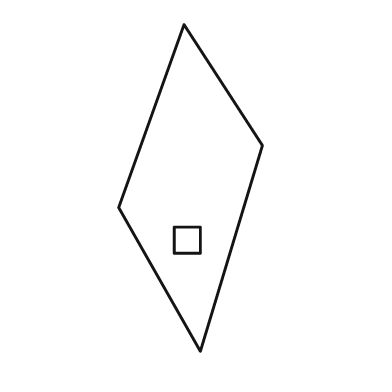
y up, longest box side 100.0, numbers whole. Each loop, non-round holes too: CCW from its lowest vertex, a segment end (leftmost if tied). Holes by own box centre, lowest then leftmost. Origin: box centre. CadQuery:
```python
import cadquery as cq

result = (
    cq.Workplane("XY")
    .moveTo(3.0, -50.0)
    .lineTo(22.0, 13.0)
    .lineTo(-2.0, 50.0)
    .lineTo(-22.0, -6.0)
    .close()
    .moveTo(-5.0, -20.0)
    .lineTo(3.0, -20.0)
    .lineTo(3.0, -12.0)
    .lineTo(-5.0, -12.0)
    .close()
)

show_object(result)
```